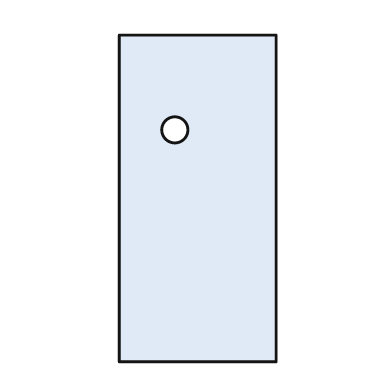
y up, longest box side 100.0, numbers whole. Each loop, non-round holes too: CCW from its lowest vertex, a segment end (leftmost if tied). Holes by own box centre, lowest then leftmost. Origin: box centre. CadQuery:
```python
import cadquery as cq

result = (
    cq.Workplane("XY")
    .moveTo(-24.0, -50.0)
    .lineTo(24.0, -50.0)
    .lineTo(24.0, 50.0)
    .lineTo(-24.0, 50.0)
    .close()
    .moveTo(-7.0, 21.0)
    .circle(4.0)
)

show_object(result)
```